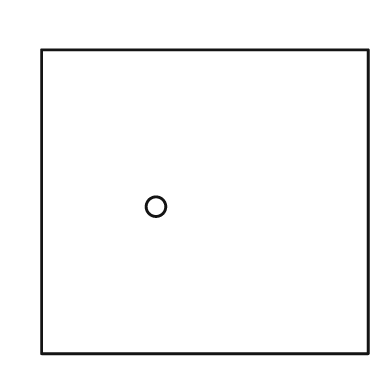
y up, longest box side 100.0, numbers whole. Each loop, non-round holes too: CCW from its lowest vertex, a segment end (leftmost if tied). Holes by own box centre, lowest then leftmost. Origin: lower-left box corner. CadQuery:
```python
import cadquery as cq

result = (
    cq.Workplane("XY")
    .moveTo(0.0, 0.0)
    .lineTo(100.0, 0.0)
    .lineTo(100.0, 93.0)
    .lineTo(0.0, 93.0)
    .close()
    .moveTo(35.0, 45.0)
    .circle(3.0)
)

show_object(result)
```